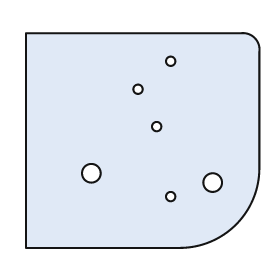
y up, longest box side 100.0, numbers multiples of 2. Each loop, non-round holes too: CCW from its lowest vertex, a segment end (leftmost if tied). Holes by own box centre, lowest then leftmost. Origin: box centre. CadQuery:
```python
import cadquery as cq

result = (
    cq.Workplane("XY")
    .moveTo(-50.0, -46.0)
    .lineTo(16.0, -46.0)
    .threePointArc((40.0, -36.0), (50.0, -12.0))
    .lineTo(50.0, 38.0)
    .threePointArc((48.0, 44.0), (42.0, 46.0))
    .lineTo(-50.0, 46.0)
    .close()
    .moveTo(12.0, -24.0)
    .circle(2.0)
    .moveTo(30.0, -18.0)
    .circle(4.0)
    .moveTo(-22.0, -14.0)
    .circle(4.0)
    .moveTo(6.0, 6.0)
    .circle(2.0)
    .moveTo(-2.0, 22.0)
    .circle(2.0)
    .moveTo(12.0, 34.0)
    .circle(2.0)
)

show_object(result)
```